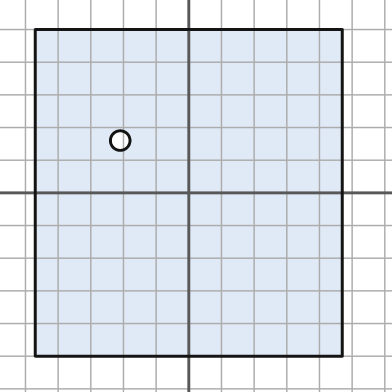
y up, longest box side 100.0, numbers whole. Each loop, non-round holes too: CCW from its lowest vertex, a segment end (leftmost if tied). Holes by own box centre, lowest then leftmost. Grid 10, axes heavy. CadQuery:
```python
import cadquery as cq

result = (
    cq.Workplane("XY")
    .moveTo(-47.0, -50.0)
    .lineTo(47.0, -50.0)
    .lineTo(47.0, 50.0)
    .lineTo(-47.0, 50.0)
    .close()
    .moveTo(-21.0, 16.0)
    .circle(3.0)
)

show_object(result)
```